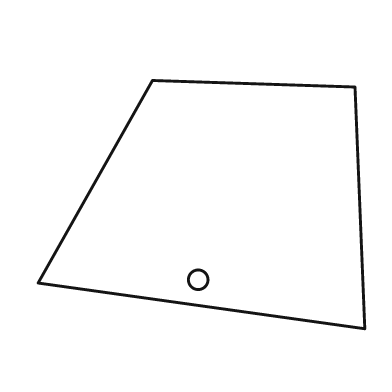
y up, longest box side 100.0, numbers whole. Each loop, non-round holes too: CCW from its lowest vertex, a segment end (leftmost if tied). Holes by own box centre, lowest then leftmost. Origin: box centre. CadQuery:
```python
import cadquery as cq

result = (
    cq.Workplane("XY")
    .moveTo(50.0, -38.0)
    .lineTo(47.0, 36.0)
    .lineTo(-15.0, 38.0)
    .lineTo(-50.0, -24.0)
    .close()
    .moveTo(-1.0, -23.0)
    .circle(3.0)
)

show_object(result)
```